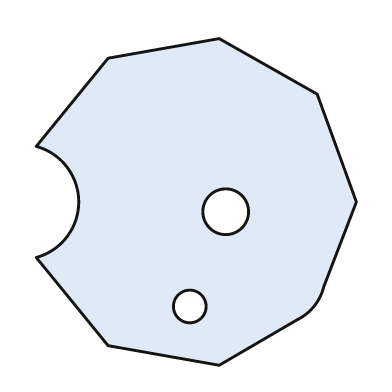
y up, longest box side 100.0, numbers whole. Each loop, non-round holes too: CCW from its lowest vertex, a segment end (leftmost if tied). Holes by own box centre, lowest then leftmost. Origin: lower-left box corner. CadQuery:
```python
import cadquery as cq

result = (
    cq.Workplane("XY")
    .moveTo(56.0, 0.0)
    .lineTo(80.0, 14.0)
    .threePointArc((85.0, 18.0), (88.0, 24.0))
    .lineTo(98.0, 50.0)
    .lineTo(86.0, 83.0)
    .lineTo(56.0, 100.0)
    .lineTo(22.0, 94.0)
    .lineTo(0.0, 67.0)
    .threePointArc((13.0, 50.0), (0.0, 33.0))
    .lineTo(22.0, 6.0)
    .close()
    .moveTo(47.0, 18.0)
    .circle(5.0)
    .moveTo(58.0, 47.0)
    .circle(7.0)
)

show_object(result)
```